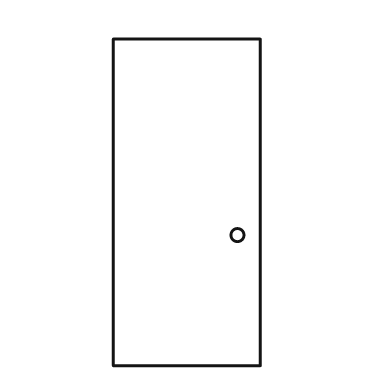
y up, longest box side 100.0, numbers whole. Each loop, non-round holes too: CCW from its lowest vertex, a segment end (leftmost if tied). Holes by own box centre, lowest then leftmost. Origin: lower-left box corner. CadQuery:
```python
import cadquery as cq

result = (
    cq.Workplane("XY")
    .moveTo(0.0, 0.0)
    .lineTo(45.0, 0.0)
    .lineTo(45.0, 100.0)
    .lineTo(0.0, 100.0)
    .close()
    .moveTo(38.0, 40.0)
    .circle(2.0)
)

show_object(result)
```